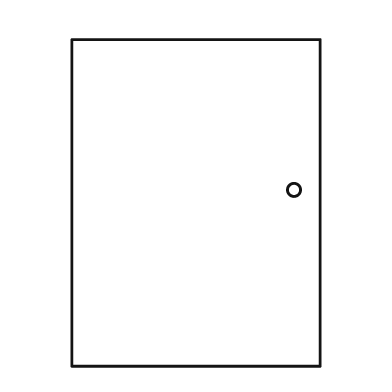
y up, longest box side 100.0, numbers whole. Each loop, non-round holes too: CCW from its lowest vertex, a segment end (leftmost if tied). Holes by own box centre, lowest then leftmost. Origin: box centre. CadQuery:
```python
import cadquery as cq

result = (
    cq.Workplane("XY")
    .moveTo(-38.0, -50.0)
    .lineTo(38.0, -50.0)
    .lineTo(38.0, 50.0)
    .lineTo(-38.0, 50.0)
    .close()
    .moveTo(30.0, 4.0)
    .circle(2.0)
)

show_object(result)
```